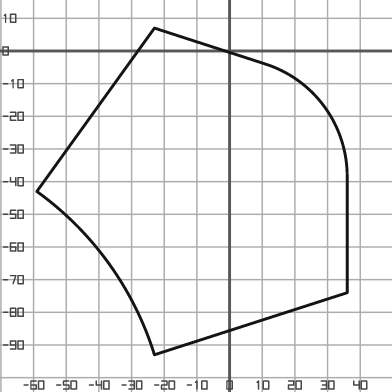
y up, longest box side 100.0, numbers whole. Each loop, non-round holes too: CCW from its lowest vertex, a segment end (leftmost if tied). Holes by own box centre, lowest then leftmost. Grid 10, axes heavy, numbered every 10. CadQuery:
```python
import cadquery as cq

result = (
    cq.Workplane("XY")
    .moveTo(-23.0, -93.0)
    .lineTo(36.0, -74.0)
    .lineTo(36.0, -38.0)
    .threePointArc((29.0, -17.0), (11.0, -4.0))
    .lineTo(-23.0, 7.0)
    .lineTo(-59.0, -43.0)
    .threePointArc((-37.0, -65.0), (-23.0, -93.0))
    .close()
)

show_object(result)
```